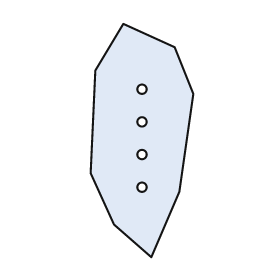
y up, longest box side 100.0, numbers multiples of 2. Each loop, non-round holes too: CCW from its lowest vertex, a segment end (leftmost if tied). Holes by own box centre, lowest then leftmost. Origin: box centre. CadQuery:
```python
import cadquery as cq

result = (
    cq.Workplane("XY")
    .moveTo(4.0, -50.0)
    .lineTo(16.0, -22.0)
    .lineTo(22.0, 20.0)
    .lineTo(14.0, 40.0)
    .lineTo(-8.0, 50.0)
    .lineTo(-20.0, 30.0)
    .lineTo(-22.0, -14.0)
    .lineTo(-12.0, -36.0)
    .close()
    .moveTo(0.0, -20.0)
    .circle(2.0)
    .moveTo(0.0, -6.0)
    .circle(2.0)
    .moveTo(0.0, 8.0)
    .circle(2.0)
    .moveTo(0.0, 22.0)
    .circle(2.0)
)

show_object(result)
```